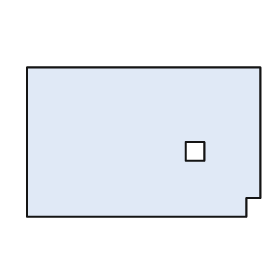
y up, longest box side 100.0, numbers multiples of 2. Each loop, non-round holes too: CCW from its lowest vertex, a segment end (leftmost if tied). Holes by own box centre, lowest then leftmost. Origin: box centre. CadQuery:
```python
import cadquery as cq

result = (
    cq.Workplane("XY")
    .moveTo(-50.0, -32.0)
    .lineTo(44.0, -32.0)
    .lineTo(44.0, -24.0)
    .lineTo(50.0, -24.0)
    .lineTo(50.0, 32.0)
    .lineTo(-50.0, 32.0)
    .close()
    .moveTo(18.0, -8.0)
    .lineTo(26.0, -8.0)
    .lineTo(26.0, 0.0)
    .lineTo(18.0, 0.0)
    .close()
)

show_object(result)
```